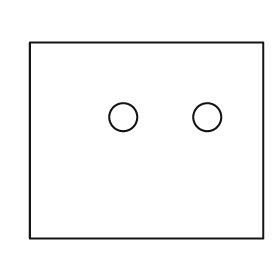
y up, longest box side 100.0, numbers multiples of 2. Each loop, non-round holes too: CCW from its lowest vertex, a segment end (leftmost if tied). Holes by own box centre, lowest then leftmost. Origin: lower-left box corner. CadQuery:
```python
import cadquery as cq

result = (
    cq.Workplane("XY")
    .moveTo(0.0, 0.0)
    .lineTo(100.0, 0.0)
    .lineTo(100.0, 84.0)
    .lineTo(0.0, 84.0)
    .close()
    .moveTo(40.0, 52.0)
    .circle(6.0)
    .moveTo(76.0, 52.0)
    .circle(6.0)
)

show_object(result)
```